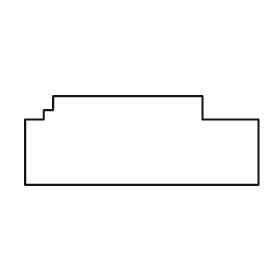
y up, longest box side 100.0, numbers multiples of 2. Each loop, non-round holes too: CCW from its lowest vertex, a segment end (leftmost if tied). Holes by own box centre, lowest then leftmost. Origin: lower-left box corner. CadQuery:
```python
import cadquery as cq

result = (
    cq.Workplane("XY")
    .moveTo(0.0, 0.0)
    .lineTo(100.0, 0.0)
    .lineTo(100.0, 28.0)
    .lineTo(76.0, 28.0)
    .lineTo(76.0, 38.0)
    .lineTo(12.0, 38.0)
    .lineTo(12.0, 32.0)
    .lineTo(8.0, 32.0)
    .lineTo(8.0, 28.0)
    .lineTo(0.0, 28.0)
    .close()
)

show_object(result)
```